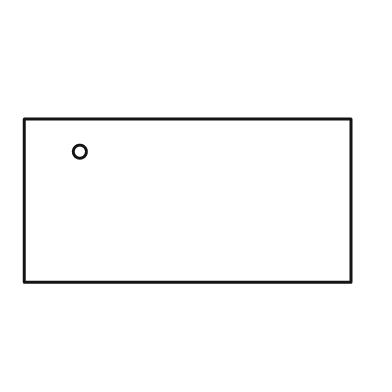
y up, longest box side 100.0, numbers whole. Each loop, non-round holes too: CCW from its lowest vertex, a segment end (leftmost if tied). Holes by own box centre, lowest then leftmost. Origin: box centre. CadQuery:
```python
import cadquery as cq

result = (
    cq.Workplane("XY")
    .moveTo(-50.0, -25.0)
    .lineTo(50.0, -25.0)
    .lineTo(50.0, 25.0)
    .lineTo(-50.0, 25.0)
    .close()
    .moveTo(-33.0, 15.0)
    .circle(2.0)
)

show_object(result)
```